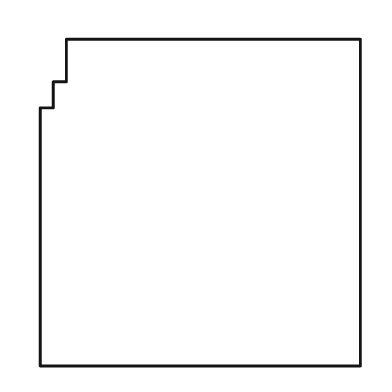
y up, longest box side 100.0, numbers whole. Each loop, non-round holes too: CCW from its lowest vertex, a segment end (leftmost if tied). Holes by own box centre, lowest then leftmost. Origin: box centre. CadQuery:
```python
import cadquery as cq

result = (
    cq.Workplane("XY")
    .moveTo(-49.0, -50.0)
    .lineTo(49.0, -50.0)
    .lineTo(49.0, 50.0)
    .lineTo(-41.0, 50.0)
    .lineTo(-41.0, 37.0)
    .lineTo(-45.0, 37.0)
    .lineTo(-45.0, 29.0)
    .lineTo(-49.0, 29.0)
    .close()
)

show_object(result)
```